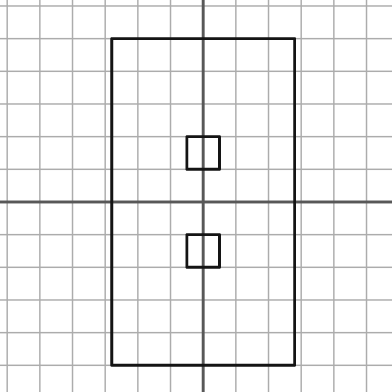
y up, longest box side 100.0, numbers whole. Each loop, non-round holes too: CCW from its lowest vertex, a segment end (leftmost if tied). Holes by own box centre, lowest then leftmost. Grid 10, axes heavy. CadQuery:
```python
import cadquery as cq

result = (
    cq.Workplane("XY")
    .moveTo(-28.0, -50.0)
    .lineTo(28.0, -50.0)
    .lineTo(28.0, 50.0)
    .lineTo(-28.0, 50.0)
    .close()
    .moveTo(-5.0, -20.0)
    .lineTo(5.0, -20.0)
    .lineTo(5.0, -10.0)
    .lineTo(-5.0, -10.0)
    .close()
    .moveTo(-5.0, 10.0)
    .lineTo(5.0, 10.0)
    .lineTo(5.0, 20.0)
    .lineTo(-5.0, 20.0)
    .close()
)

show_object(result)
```